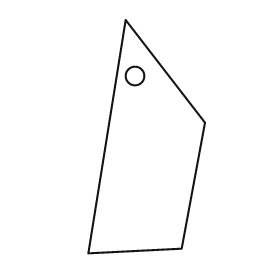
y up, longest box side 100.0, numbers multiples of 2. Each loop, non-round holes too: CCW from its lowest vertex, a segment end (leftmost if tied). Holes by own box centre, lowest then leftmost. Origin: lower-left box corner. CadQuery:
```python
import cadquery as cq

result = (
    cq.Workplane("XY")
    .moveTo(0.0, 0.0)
    .lineTo(40.0, 2.0)
    .lineTo(50.0, 56.0)
    .lineTo(16.0, 100.0)
    .close()
    .moveTo(20.0, 76.0)
    .circle(4.0)
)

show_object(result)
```